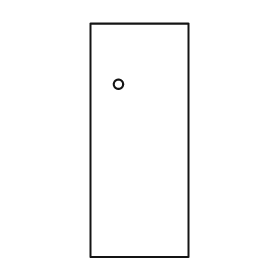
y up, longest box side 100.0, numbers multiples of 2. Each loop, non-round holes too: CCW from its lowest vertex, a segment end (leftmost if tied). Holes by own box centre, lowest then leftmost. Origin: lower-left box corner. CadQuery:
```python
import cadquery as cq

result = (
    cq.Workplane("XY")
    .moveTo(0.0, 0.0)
    .lineTo(42.0, 0.0)
    .lineTo(42.0, 100.0)
    .lineTo(0.0, 100.0)
    .close()
    .moveTo(12.0, 74.0)
    .circle(2.0)
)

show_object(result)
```